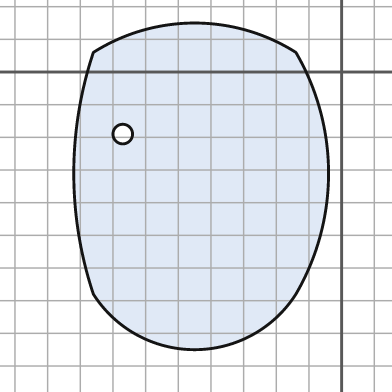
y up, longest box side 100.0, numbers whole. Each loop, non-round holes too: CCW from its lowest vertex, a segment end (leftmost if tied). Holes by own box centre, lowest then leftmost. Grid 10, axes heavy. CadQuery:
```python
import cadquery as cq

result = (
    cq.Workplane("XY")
    .moveTo(-76.0, -68.0)
    .threePointArc((-45.0, -85.0), (-14.0, -68.0))
    .threePointArc((-4.0, -31.0), (-14.0, 6.0))
    .threePointArc((-45.0, 15.0), (-76.0, 6.0))
    .threePointArc((-82.0, -31.0), (-76.0, -68.0))
    .close()
    .moveTo(-67.0, -19.0)
    .circle(3.0)
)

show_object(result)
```